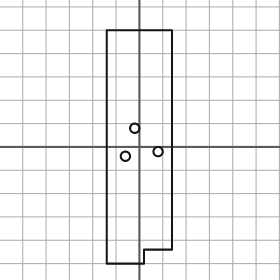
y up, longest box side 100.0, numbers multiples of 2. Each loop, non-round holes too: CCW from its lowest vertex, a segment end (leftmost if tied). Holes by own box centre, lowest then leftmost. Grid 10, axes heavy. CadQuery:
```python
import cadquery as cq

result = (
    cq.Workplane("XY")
    .moveTo(-14.0, -50.0)
    .lineTo(2.0, -50.0)
    .lineTo(2.0, -44.0)
    .lineTo(14.0, -44.0)
    .lineTo(14.0, 50.0)
    .lineTo(-14.0, 50.0)
    .close()
    .moveTo(-6.0, -4.0)
    .circle(2.0)
    .moveTo(8.0, -2.0)
    .circle(2.0)
    .moveTo(-2.0, 8.0)
    .circle(2.0)
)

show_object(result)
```